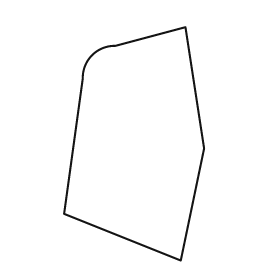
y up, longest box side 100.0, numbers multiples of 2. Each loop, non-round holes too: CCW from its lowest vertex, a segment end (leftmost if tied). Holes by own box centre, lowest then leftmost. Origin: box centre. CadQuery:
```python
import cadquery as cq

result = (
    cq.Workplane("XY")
    .moveTo(20.0, -50.0)
    .lineTo(30.0, -2.0)
    .lineTo(22.0, 50.0)
    .lineTo(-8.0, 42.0)
    .threePointArc((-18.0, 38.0), (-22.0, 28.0))
    .lineTo(-30.0, -30.0)
    .close()
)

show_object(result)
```